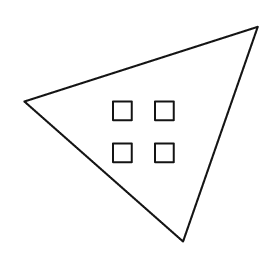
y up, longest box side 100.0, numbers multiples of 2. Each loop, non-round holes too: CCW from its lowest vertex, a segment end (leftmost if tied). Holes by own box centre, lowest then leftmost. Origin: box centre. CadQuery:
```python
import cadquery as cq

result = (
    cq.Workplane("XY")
    .moveTo(18.0, -46.0)
    .lineTo(50.0, 46.0)
    .lineTo(-50.0, 14.0)
    .close()
    .moveTo(-12.0, -12.0)
    .lineTo(-4.0, -12.0)
    .lineTo(-4.0, -4.0)
    .lineTo(-12.0, -4.0)
    .close()
    .moveTo(6.0, -12.0)
    .lineTo(14.0, -12.0)
    .lineTo(14.0, -4.0)
    .lineTo(6.0, -4.0)
    .close()
    .moveTo(-12.0, 6.0)
    .lineTo(-4.0, 6.0)
    .lineTo(-4.0, 14.0)
    .lineTo(-12.0, 14.0)
    .close()
    .moveTo(6.0, 6.0)
    .lineTo(14.0, 6.0)
    .lineTo(14.0, 14.0)
    .lineTo(6.0, 14.0)
    .close()
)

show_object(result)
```